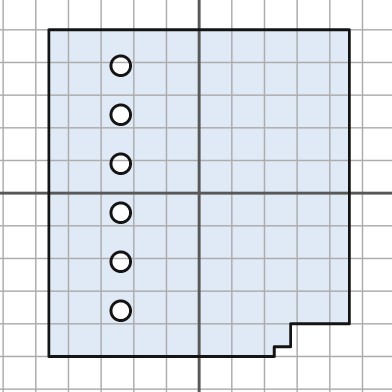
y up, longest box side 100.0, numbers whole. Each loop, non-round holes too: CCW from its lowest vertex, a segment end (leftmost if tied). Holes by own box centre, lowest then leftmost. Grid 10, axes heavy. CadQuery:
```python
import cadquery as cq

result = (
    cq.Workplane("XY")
    .moveTo(-46.0, -50.0)
    .lineTo(23.0, -50.0)
    .lineTo(23.0, -47.0)
    .lineTo(28.0, -47.0)
    .lineTo(28.0, -40.0)
    .lineTo(46.0, -40.0)
    .lineTo(46.0, 50.0)
    .lineTo(-46.0, 50.0)
    .close()
    .moveTo(-24.0, -36.0)
    .circle(3.0)
    .moveTo(-24.0, -21.0)
    .circle(3.0)
    .moveTo(-24.0, -6.0)
    .circle(3.0)
    .moveTo(-24.0, 9.0)
    .circle(3.0)
    .moveTo(-24.0, 24.0)
    .circle(3.0)
    .moveTo(-24.0, 39.0)
    .circle(3.0)
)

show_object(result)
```